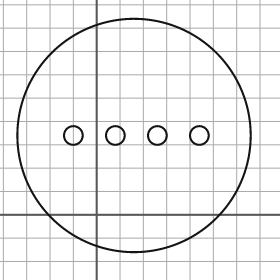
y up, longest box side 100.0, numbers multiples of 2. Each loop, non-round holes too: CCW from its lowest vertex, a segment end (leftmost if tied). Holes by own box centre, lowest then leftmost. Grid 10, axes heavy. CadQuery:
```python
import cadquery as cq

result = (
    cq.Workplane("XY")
    .moveTo(16.0, 34.0)
    .circle(50.0)
    .moveTo(-10.0, 34.0)
    .circle(4.0)
    .moveTo(8.0, 34.0)
    .circle(4.0)
    .moveTo(26.0, 34.0)
    .circle(4.0)
    .moveTo(44.0, 34.0)
    .circle(4.0)
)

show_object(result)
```